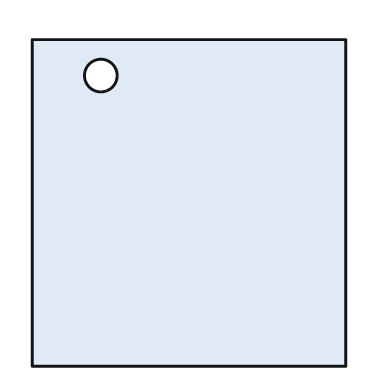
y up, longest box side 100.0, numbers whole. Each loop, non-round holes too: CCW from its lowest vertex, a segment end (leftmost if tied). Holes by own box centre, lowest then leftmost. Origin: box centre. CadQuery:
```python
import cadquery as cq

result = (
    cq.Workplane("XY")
    .moveTo(-48.0, -50.0)
    .lineTo(48.0, -50.0)
    .lineTo(48.0, 50.0)
    .lineTo(-48.0, 50.0)
    .close()
    .moveTo(-27.0, 39.0)
    .circle(5.0)
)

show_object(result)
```